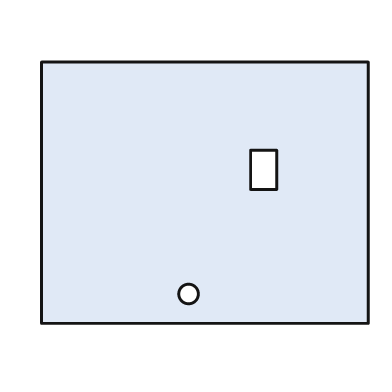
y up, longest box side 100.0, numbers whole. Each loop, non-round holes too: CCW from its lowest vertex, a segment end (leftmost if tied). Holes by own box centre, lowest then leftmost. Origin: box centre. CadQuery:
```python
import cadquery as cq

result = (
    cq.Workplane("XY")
    .moveTo(-50.0, -40.0)
    .lineTo(50.0, -40.0)
    .lineTo(50.0, 40.0)
    .lineTo(-50.0, 40.0)
    .close()
    .moveTo(-5.0, -31.0)
    .circle(3.0)
    .moveTo(14.0, 1.0)
    .lineTo(22.0, 1.0)
    .lineTo(22.0, 13.0)
    .lineTo(14.0, 13.0)
    .close()
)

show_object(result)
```